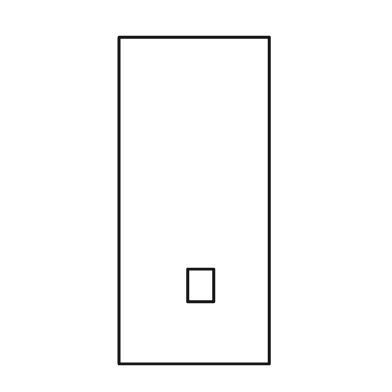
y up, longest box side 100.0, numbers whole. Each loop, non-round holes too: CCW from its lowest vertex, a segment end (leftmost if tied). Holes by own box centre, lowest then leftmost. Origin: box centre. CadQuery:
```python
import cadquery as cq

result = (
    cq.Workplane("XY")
    .moveTo(-23.0, -50.0)
    .lineTo(23.0, -50.0)
    .lineTo(23.0, 50.0)
    .lineTo(-23.0, 50.0)
    .close()
    .moveTo(-2.0, -31.0)
    .lineTo(6.0, -31.0)
    .lineTo(6.0, -21.0)
    .lineTo(-2.0, -21.0)
    .close()
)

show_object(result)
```